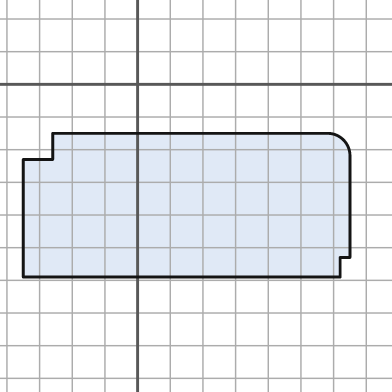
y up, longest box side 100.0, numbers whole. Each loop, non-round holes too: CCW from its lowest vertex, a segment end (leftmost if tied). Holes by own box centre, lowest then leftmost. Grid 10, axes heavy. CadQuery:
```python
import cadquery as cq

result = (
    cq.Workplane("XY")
    .moveTo(-35.0, -59.0)
    .lineTo(62.0, -59.0)
    .lineTo(62.0, -53.0)
    .lineTo(65.0, -53.0)
    .lineTo(65.0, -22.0)
    .threePointArc((63.0, -17.0), (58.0, -15.0))
    .lineTo(-26.0, -15.0)
    .lineTo(-26.0, -23.0)
    .lineTo(-35.0, -23.0)
    .close()
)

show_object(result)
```